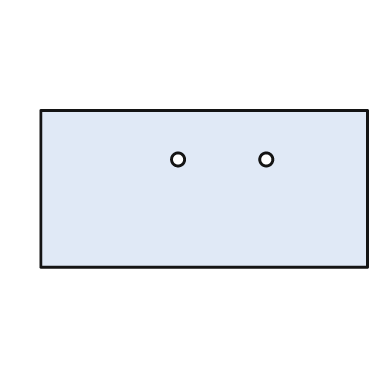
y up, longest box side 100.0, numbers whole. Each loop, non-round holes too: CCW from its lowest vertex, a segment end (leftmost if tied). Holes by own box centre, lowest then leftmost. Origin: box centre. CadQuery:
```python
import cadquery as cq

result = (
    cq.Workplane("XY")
    .moveTo(-50.0, -24.0)
    .lineTo(50.0, -24.0)
    .lineTo(50.0, 24.0)
    .lineTo(-50.0, 24.0)
    .close()
    .moveTo(-8.0, 9.0)
    .circle(2.0)
    .moveTo(19.0, 9.0)
    .circle(2.0)
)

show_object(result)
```